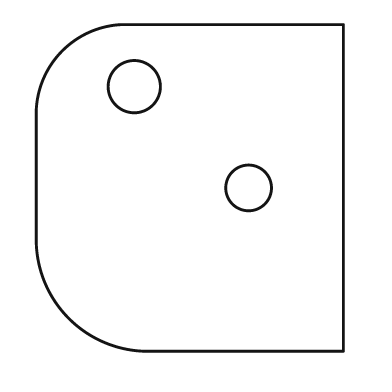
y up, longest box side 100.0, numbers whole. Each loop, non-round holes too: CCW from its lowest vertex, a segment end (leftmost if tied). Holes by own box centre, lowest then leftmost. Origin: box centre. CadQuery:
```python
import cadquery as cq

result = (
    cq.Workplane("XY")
    .moveTo(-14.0, -50.0)
    .lineTo(47.0, -50.0)
    .lineTo(47.0, 50.0)
    .lineTo(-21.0, 50.0)
    .threePointArc((-39.0, 42.0), (-47.0, 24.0))
    .lineTo(-47.0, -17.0)
    .threePointArc((-37.0, -40.0), (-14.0, -50.0))
    .close()
    .moveTo(18.0, 0.0)
    .circle(7.0)
    .moveTo(-17.0, 31.0)
    .circle(8.0)
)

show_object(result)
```